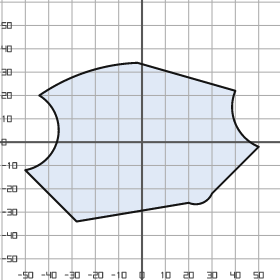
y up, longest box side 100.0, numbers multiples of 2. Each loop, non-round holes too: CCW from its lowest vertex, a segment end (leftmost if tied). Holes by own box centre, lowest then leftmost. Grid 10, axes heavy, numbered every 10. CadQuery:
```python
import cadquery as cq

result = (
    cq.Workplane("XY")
    .moveTo(-28.0, -34.0)
    .lineTo(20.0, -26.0)
    .threePointArc((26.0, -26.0), (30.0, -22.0))
    .lineTo(50.0, -2.0)
    .threePointArc((40.0, 8.0), (40.0, 22.0))
    .lineTo(-2.0, 34.0)
    .threePointArc((-24.0, 30.0), (-44.0, 20.0))
    .threePointArc((-36.0, 2.0), (-50.0, -12.0))
    .close()
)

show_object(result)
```